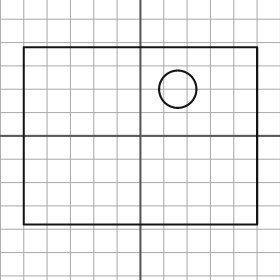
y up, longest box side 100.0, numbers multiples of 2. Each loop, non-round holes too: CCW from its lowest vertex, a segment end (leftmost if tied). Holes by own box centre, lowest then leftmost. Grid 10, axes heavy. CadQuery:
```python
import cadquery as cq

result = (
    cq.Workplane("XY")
    .moveTo(-50.0, -38.0)
    .lineTo(50.0, -38.0)
    .lineTo(50.0, 38.0)
    .lineTo(-50.0, 38.0)
    .close()
    .moveTo(16.0, 20.0)
    .circle(8.0)
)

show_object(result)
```